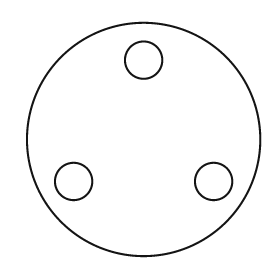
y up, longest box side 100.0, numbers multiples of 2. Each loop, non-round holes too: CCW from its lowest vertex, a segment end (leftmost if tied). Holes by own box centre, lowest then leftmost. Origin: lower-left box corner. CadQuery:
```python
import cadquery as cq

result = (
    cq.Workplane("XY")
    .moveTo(50.0, 50.0)
    .circle(50.0)
    .moveTo(20.0, 32.0)
    .circle(8.0)
    .moveTo(80.0, 32.0)
    .circle(8.0)
    .moveTo(50.0, 84.0)
    .circle(8.0)
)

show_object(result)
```